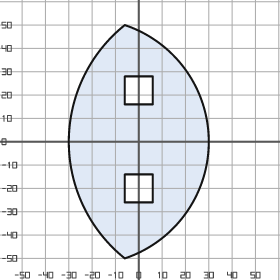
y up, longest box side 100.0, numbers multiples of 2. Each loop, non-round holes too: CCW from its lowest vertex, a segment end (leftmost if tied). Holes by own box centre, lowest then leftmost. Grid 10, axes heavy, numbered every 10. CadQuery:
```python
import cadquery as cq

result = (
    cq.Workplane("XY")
    .moveTo(-6.0, -50.0)
    .threePointArc((30.0, 0.0), (-6.0, 50.0))
    .threePointArc((-30.0, 0.0), (-6.0, -50.0))
    .close()
    .moveTo(-6.0, -26.0)
    .lineTo(6.0, -26.0)
    .lineTo(6.0, -14.0)
    .lineTo(-6.0, -14.0)
    .close()
    .moveTo(-6.0, 16.0)
    .lineTo(6.0, 16.0)
    .lineTo(6.0, 28.0)
    .lineTo(-6.0, 28.0)
    .close()
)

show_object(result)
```